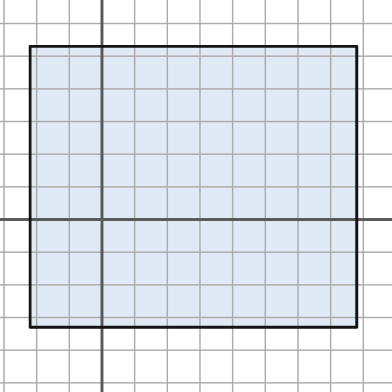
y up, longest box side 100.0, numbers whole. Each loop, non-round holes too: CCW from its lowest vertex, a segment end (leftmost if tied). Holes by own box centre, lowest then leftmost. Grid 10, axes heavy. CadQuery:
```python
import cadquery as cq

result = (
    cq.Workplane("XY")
    .moveTo(-22.0, -33.0)
    .lineTo(78.0, -33.0)
    .lineTo(78.0, 53.0)
    .lineTo(-22.0, 53.0)
    .close()
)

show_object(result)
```